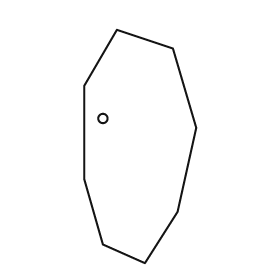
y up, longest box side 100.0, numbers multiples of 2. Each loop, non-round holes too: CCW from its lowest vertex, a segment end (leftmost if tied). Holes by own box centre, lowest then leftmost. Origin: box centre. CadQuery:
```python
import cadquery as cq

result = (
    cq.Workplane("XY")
    .moveTo(2.0, -50.0)
    .lineTo(16.0, -28.0)
    .lineTo(24.0, 8.0)
    .lineTo(14.0, 42.0)
    .lineTo(-10.0, 50.0)
    .lineTo(-24.0, 26.0)
    .lineTo(-24.0, -14.0)
    .lineTo(-16.0, -42.0)
    .close()
    .moveTo(-16.0, 12.0)
    .circle(2.0)
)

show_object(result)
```